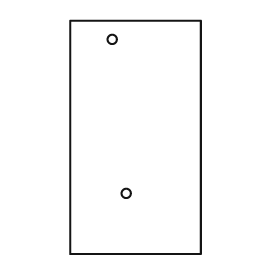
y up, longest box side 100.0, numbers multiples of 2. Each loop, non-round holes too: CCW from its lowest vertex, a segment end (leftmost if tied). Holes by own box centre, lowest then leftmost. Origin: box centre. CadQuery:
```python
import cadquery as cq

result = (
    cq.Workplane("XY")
    .moveTo(-28.0, -50.0)
    .lineTo(28.0, -50.0)
    .lineTo(28.0, 50.0)
    .lineTo(-28.0, 50.0)
    .close()
    .moveTo(-4.0, -24.0)
    .circle(2.0)
    .moveTo(-10.0, 42.0)
    .circle(2.0)
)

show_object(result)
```